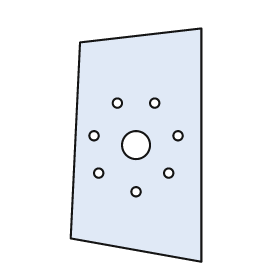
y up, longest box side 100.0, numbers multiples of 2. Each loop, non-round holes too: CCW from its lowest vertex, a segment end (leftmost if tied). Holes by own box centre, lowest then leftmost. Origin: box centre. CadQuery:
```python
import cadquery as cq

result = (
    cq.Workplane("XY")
    .moveTo(28.0, -50.0)
    .lineTo(28.0, 50.0)
    .lineTo(-24.0, 44.0)
    .lineTo(-28.0, -40.0)
    .close()
    .moveTo(0.0, -20.0)
    .circle(2.0)
    .moveTo(-16.0, -12.0)
    .circle(2.0)
    .moveTo(14.0, -12.0)
    .circle(2.0)
    .moveTo(0.0, 0.0)
    .circle(6.0)
    .moveTo(-18.0, 4.0)
    .circle(2.0)
    .moveTo(18.0, 4.0)
    .circle(2.0)
    .moveTo(-8.0, 18.0)
    .circle(2.0)
    .moveTo(8.0, 18.0)
    .circle(2.0)
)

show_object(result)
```